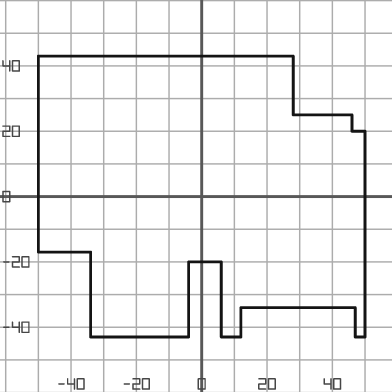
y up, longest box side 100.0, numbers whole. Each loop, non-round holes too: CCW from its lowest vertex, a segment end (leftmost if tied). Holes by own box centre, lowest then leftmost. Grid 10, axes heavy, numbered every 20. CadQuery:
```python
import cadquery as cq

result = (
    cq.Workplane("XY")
    .moveTo(-34.0, -43.0)
    .lineTo(-4.0, -43.0)
    .lineTo(-4.0, -20.0)
    .lineTo(6.0, -20.0)
    .lineTo(6.0, -43.0)
    .lineTo(12.0, -43.0)
    .lineTo(12.0, -34.0)
    .lineTo(47.0, -34.0)
    .lineTo(47.0, -43.0)
    .lineTo(50.0, -43.0)
    .lineTo(50.0, 20.0)
    .lineTo(46.0, 20.0)
    .lineTo(46.0, 25.0)
    .lineTo(28.0, 25.0)
    .lineTo(28.0, 43.0)
    .lineTo(-50.0, 43.0)
    .lineTo(-50.0, -17.0)
    .lineTo(-34.0, -17.0)
    .close()
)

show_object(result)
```